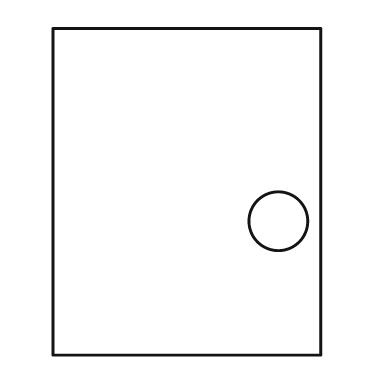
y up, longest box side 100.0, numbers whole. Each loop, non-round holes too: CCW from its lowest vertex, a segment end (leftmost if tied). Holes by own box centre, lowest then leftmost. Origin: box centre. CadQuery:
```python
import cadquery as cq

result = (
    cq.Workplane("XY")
    .moveTo(-41.0, -50.0)
    .lineTo(41.0, -50.0)
    .lineTo(41.0, 50.0)
    .lineTo(-41.0, 50.0)
    .close()
    .moveTo(28.0, -9.0)
    .circle(9.0)
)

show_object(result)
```